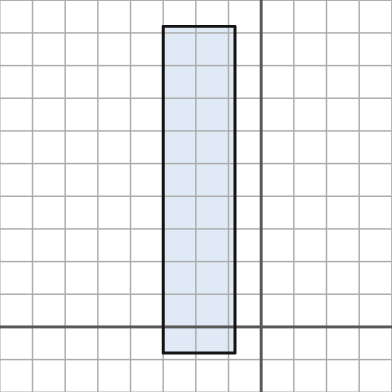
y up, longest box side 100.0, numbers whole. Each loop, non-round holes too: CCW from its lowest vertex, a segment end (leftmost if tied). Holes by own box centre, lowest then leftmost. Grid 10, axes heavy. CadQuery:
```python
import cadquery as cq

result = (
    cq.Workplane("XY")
    .moveTo(-30.0, -8.0)
    .lineTo(-8.0, -8.0)
    .lineTo(-8.0, 92.0)
    .lineTo(-30.0, 92.0)
    .close()
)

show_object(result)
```